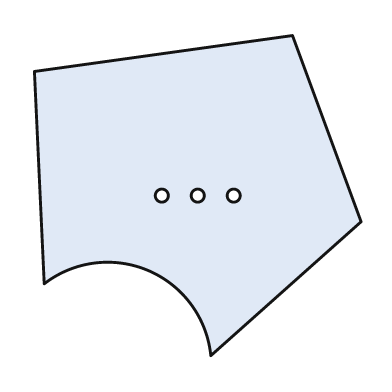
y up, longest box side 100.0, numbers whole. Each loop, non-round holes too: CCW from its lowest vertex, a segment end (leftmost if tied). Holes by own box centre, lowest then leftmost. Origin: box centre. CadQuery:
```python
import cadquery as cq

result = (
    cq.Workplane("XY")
    .moveTo(4.0, -49.0)
    .lineTo(50.0, -8.0)
    .lineTo(29.0, 49.0)
    .lineTo(-50.0, 38.0)
    .lineTo(-47.0, -27.0)
    .threePointArc((-15.0, -23.0), (4.0, -49.0))
    .close()
    .moveTo(-11.0, 0.0)
    .circle(2.0)
    .moveTo(0.0, 0.0)
    .circle(2.0)
    .moveTo(11.0, 0.0)
    .circle(2.0)
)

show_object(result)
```